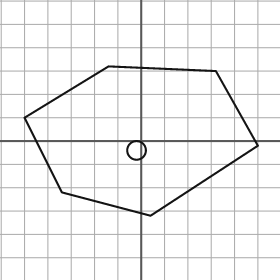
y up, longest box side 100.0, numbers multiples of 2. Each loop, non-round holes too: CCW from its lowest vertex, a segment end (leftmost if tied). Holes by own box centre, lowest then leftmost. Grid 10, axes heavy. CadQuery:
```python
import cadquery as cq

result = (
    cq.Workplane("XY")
    .moveTo(4.0, -32.0)
    .lineTo(50.0, -2.0)
    .lineTo(32.0, 30.0)
    .lineTo(-14.0, 32.0)
    .lineTo(-50.0, 10.0)
    .lineTo(-34.0, -22.0)
    .close()
    .moveTo(-2.0, -4.0)
    .circle(4.0)
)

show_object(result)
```